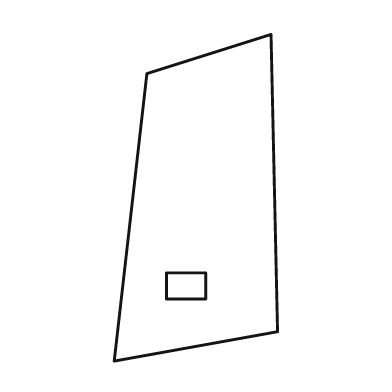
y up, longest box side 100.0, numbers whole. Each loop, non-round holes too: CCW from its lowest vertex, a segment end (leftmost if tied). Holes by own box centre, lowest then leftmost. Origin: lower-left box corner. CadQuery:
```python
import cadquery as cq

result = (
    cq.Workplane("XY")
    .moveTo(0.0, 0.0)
    .lineTo(50.0, 9.0)
    .lineTo(48.0, 100.0)
    .lineTo(10.0, 88.0)
    .close()
    .moveTo(16.0, 19.0)
    .lineTo(28.0, 19.0)
    .lineTo(28.0, 27.0)
    .lineTo(16.0, 27.0)
    .close()
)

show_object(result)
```